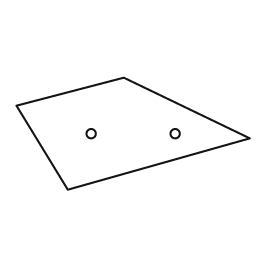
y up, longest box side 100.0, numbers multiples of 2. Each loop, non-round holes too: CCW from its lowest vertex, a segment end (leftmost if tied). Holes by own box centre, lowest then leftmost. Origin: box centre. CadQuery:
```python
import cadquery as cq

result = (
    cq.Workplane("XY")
    .moveTo(-28.0, -24.0)
    .lineTo(50.0, -2.0)
    .lineTo(-4.0, 24.0)
    .lineTo(-50.0, 12.0)
    .close()
    .moveTo(-18.0, 0.0)
    .circle(2.0)
    .moveTo(18.0, 0.0)
    .circle(2.0)
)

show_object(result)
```